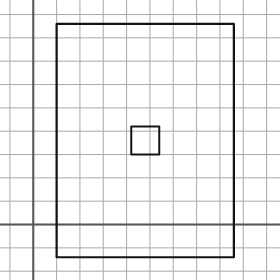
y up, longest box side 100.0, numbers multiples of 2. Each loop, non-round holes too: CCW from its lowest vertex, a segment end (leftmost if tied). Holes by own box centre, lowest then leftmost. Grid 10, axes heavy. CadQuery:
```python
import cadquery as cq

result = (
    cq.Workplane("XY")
    .moveTo(10.0, -14.0)
    .lineTo(86.0, -14.0)
    .lineTo(86.0, 86.0)
    .lineTo(10.0, 86.0)
    .close()
    .moveTo(42.0, 30.0)
    .lineTo(54.0, 30.0)
    .lineTo(54.0, 42.0)
    .lineTo(42.0, 42.0)
    .close()
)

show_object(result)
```